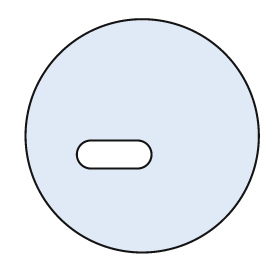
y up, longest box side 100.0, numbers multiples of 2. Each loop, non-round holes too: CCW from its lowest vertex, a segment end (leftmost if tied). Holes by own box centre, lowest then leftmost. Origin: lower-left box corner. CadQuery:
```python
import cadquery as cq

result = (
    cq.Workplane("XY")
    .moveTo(50.0, 50.0)
    .circle(50.0)
    .moveTo(28.0, 36.0)
    .lineTo(48.0, 36.0)
    .threePointArc((54.0, 42.0), (48.0, 48.0))
    .lineTo(28.0, 48.0)
    .threePointArc((22.0, 42.0), (28.0, 36.0))
    .close()
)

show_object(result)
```